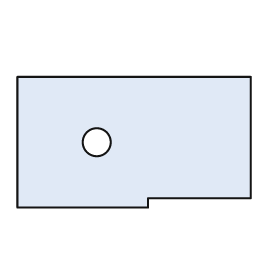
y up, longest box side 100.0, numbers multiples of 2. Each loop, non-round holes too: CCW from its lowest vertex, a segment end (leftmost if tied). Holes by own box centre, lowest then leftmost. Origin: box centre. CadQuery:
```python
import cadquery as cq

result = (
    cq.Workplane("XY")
    .moveTo(-50.0, -28.0)
    .lineTo(6.0, -28.0)
    .lineTo(6.0, -24.0)
    .lineTo(50.0, -24.0)
    .lineTo(50.0, 28.0)
    .lineTo(-50.0, 28.0)
    .close()
    .moveTo(-16.0, 0.0)
    .circle(6.0)
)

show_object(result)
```